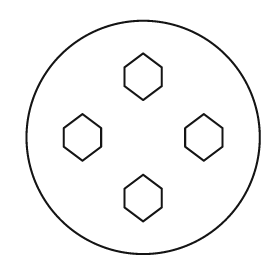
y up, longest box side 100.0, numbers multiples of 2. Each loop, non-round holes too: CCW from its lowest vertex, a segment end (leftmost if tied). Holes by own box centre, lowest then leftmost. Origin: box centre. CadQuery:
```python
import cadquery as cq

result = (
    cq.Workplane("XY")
    .moveTo(0.0, 0.0)
    .circle(50.0)
    .moveTo(0.0, -36.0)
    .lineTo(8.0, -30.0)
    .lineTo(8.0, -22.0)
    .lineTo(0.0, -16.0)
    .lineTo(-8.0, -22.0)
    .lineTo(-8.0, -30.0)
    .close()
    .moveTo(-26.0, -10.0)
    .lineTo(-18.0, -4.0)
    .lineTo(-18.0, 4.0)
    .lineTo(-26.0, 10.0)
    .lineTo(-34.0, 4.0)
    .lineTo(-34.0, -4.0)
    .close()
    .moveTo(26.0, -10.0)
    .lineTo(34.0, -4.0)
    .lineTo(34.0, 4.0)
    .lineTo(26.0, 10.0)
    .lineTo(18.0, 4.0)
    .lineTo(18.0, -4.0)
    .close()
    .moveTo(0.0, 16.0)
    .lineTo(8.0, 22.0)
    .lineTo(8.0, 30.0)
    .lineTo(0.0, 36.0)
    .lineTo(-8.0, 30.0)
    .lineTo(-8.0, 22.0)
    .close()
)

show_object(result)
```